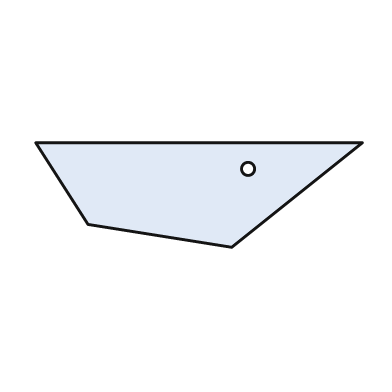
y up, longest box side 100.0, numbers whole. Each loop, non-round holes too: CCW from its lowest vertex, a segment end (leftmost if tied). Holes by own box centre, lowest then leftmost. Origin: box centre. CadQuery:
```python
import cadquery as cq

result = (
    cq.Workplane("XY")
    .moveTo(10.0, -16.0)
    .lineTo(50.0, 16.0)
    .lineTo(-50.0, 16.0)
    .lineTo(-34.0, -9.0)
    .close()
    .moveTo(15.0, 8.0)
    .circle(2.0)
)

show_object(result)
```